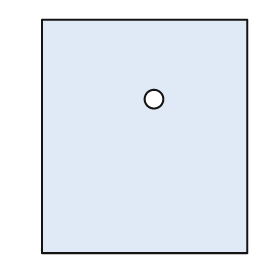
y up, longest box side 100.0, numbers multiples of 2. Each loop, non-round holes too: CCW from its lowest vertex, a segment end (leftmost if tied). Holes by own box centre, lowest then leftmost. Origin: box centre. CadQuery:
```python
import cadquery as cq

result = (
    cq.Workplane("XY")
    .moveTo(-44.0, -50.0)
    .lineTo(44.0, -50.0)
    .lineTo(44.0, 50.0)
    .lineTo(-44.0, 50.0)
    .close()
    .moveTo(4.0, 16.0)
    .circle(4.0)
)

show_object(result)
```